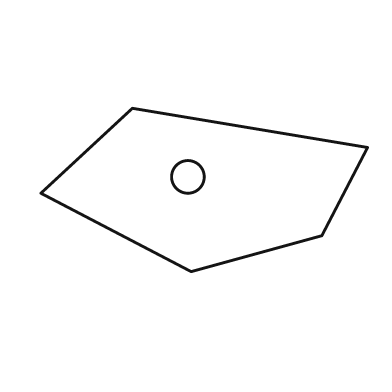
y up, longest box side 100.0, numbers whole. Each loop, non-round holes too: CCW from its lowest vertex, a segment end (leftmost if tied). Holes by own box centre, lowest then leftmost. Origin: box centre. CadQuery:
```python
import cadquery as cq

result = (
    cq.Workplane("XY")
    .moveTo(-4.0, -25.0)
    .lineTo(36.0, -14.0)
    .lineTo(50.0, 13.0)
    .lineTo(-22.0, 25.0)
    .lineTo(-50.0, -1.0)
    .close()
    .moveTo(-5.0, 4.0)
    .circle(5.0)
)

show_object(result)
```